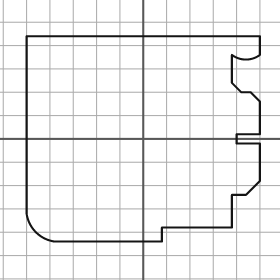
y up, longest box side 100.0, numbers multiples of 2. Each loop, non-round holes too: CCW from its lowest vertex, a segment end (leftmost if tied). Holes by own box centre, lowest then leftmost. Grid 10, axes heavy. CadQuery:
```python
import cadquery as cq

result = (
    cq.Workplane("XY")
    .moveTo(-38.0, -44.0)
    .lineTo(8.0, -44.0)
    .lineTo(8.0, -38.0)
    .lineTo(38.0, -38.0)
    .lineTo(38.0, -24.0)
    .lineTo(44.0, -24.0)
    .lineTo(50.0, -18.0)
    .lineTo(50.0, -2.0)
    .lineTo(40.0, -2.0)
    .lineTo(40.0, 2.0)
    .lineTo(50.0, 2.0)
    .lineTo(50.0, 16.0)
    .lineTo(46.0, 20.0)
    .lineTo(42.0, 20.0)
    .lineTo(38.0, 24.0)
    .lineTo(38.0, 36.0)
    .threePointArc((44.0, 34.0), (50.0, 36.0))
    .lineTo(50.0, 44.0)
    .lineTo(-50.0, 44.0)
    .lineTo(-50.0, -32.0)
    .threePointArc((-46.0, -40.0), (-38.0, -44.0))
    .close()
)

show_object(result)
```